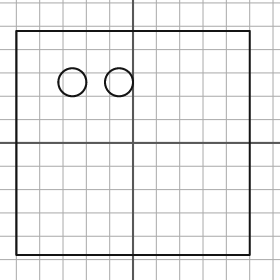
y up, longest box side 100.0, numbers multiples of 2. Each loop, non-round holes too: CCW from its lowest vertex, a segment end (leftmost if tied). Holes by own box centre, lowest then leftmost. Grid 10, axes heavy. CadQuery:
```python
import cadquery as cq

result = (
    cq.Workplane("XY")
    .moveTo(-50.0, -48.0)
    .lineTo(50.0, -48.0)
    .lineTo(50.0, 48.0)
    .lineTo(-50.0, 48.0)
    .close()
    .moveTo(-26.0, 26.0)
    .circle(6.0)
    .moveTo(-6.0, 26.0)
    .circle(6.0)
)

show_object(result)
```